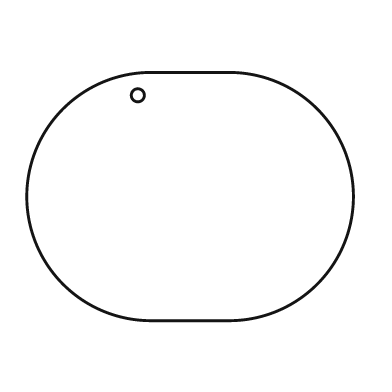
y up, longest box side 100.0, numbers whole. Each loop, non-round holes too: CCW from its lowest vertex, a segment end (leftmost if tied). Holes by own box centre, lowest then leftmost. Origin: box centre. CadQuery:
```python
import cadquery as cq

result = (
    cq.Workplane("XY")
    .moveTo(-12.0, -38.0)
    .lineTo(12.0, -38.0)
    .threePointArc((50.0, 0.0), (12.0, 38.0))
    .lineTo(-12.0, 38.0)
    .threePointArc((-50.0, 0.0), (-12.0, -38.0))
    .close()
    .moveTo(-16.0, 31.0)
    .circle(2.0)
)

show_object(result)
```